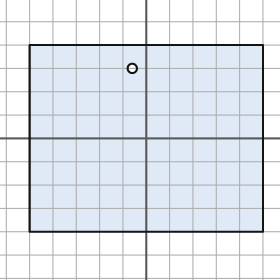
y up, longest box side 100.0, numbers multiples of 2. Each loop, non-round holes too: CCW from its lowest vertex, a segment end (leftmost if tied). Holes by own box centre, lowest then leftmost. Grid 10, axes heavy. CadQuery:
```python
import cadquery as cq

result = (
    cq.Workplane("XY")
    .moveTo(-50.0, -40.0)
    .lineTo(50.0, -40.0)
    .lineTo(50.0, 40.0)
    .lineTo(-50.0, 40.0)
    .close()
    .moveTo(-6.0, 30.0)
    .circle(2.0)
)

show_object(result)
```